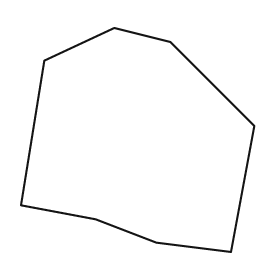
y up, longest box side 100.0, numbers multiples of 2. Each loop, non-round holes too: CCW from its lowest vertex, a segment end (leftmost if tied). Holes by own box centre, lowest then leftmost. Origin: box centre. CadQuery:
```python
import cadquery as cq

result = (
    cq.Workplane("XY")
    .moveTo(40.0, -48.0)
    .lineTo(50.0, 6.0)
    .lineTo(14.0, 42.0)
    .lineTo(-10.0, 48.0)
    .lineTo(-40.0, 34.0)
    .lineTo(-50.0, -28.0)
    .lineTo(-18.0, -34.0)
    .lineTo(8.0, -44.0)
    .close()
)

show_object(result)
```